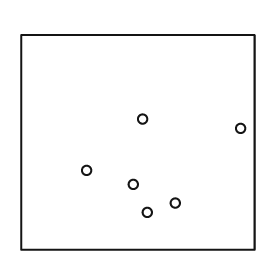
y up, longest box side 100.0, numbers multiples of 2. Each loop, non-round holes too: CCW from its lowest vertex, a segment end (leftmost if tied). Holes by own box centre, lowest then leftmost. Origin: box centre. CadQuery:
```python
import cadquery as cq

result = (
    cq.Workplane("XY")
    .moveTo(-50.0, -46.0)
    .lineTo(50.0, -46.0)
    .lineTo(50.0, 46.0)
    .lineTo(-50.0, 46.0)
    .close()
    .moveTo(4.0, -30.0)
    .circle(2.0)
    .moveTo(16.0, -26.0)
    .circle(2.0)
    .moveTo(-2.0, -18.0)
    .circle(2.0)
    .moveTo(-22.0, -12.0)
    .circle(2.0)
    .moveTo(44.0, 6.0)
    .circle(2.0)
    .moveTo(2.0, 10.0)
    .circle(2.0)
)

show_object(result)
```